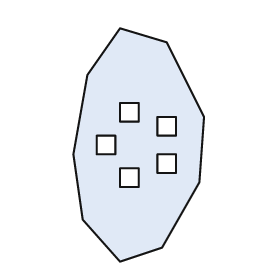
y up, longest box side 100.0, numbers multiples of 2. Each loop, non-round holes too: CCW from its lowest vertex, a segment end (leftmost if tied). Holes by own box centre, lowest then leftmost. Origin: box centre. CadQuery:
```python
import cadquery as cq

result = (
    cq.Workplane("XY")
    .moveTo(-8.0, -50.0)
    .lineTo(10.0, -44.0)
    .lineTo(26.0, -16.0)
    .lineTo(28.0, 12.0)
    .lineTo(12.0, 44.0)
    .lineTo(-8.0, 50.0)
    .lineTo(-22.0, 30.0)
    .lineTo(-28.0, -4.0)
    .lineTo(-24.0, -32.0)
    .close()
    .moveTo(-8.0, -18.0)
    .lineTo(0.0, -18.0)
    .lineTo(0.0, -10.0)
    .lineTo(-8.0, -10.0)
    .close()
    .moveTo(8.0, -12.0)
    .lineTo(16.0, -12.0)
    .lineTo(16.0, -4.0)
    .lineTo(8.0, -4.0)
    .close()
    .moveTo(-18.0, -4.0)
    .lineTo(-10.0, -4.0)
    .lineTo(-10.0, 4.0)
    .lineTo(-18.0, 4.0)
    .close()
    .moveTo(8.0, 4.0)
    .lineTo(16.0, 4.0)
    .lineTo(16.0, 12.0)
    .lineTo(8.0, 12.0)
    .close()
    .moveTo(-8.0, 10.0)
    .lineTo(0.0, 10.0)
    .lineTo(0.0, 18.0)
    .lineTo(-8.0, 18.0)
    .close()
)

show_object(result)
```